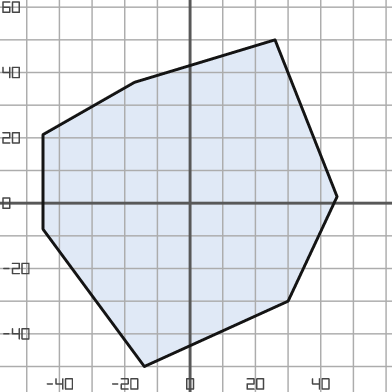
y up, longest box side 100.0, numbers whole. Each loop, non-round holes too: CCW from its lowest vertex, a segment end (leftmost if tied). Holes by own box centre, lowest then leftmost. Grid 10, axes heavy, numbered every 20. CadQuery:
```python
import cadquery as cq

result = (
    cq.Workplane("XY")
    .moveTo(-14.0, -50.0)
    .lineTo(30.0, -30.0)
    .lineTo(45.0, 2.0)
    .lineTo(26.0, 50.0)
    .lineTo(-17.0, 37.0)
    .lineTo(-45.0, 21.0)
    .lineTo(-45.0, -8.0)
    .close()
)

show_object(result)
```